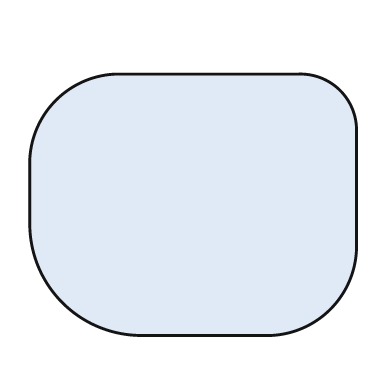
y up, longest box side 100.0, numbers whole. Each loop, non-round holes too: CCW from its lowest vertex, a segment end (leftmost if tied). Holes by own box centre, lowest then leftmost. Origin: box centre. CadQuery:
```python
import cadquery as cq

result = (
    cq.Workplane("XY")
    .moveTo(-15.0, -40.0)
    .lineTo(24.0, -40.0)
    .threePointArc((42.0, -32.0), (50.0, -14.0))
    .lineTo(50.0, 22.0)
    .threePointArc((45.0, 35.0), (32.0, 40.0))
    .lineTo(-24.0, 40.0)
    .threePointArc((-42.0, 32.0), (-50.0, 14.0))
    .lineTo(-50.0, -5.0)
    .threePointArc((-40.0, -30.0), (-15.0, -40.0))
    .close()
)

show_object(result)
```